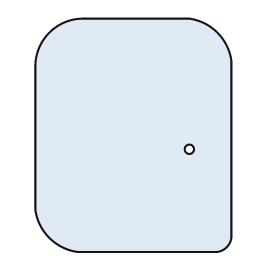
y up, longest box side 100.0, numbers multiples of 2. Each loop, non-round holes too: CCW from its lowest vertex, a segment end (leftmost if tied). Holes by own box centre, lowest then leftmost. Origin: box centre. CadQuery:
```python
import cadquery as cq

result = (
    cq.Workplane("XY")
    .moveTo(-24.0, -50.0)
    .lineTo(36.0, -50.0)
    .threePointArc((40.0, -48.0), (42.0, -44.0))
    .lineTo(42.0, 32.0)
    .threePointArc((36.0, 44.0), (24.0, 50.0))
    .lineTo(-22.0, 50.0)
    .threePointArc((-36.0, 44.0), (-42.0, 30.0))
    .lineTo(-42.0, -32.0)
    .threePointArc((-36.0, -44.0), (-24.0, -50.0))
    .close()
    .moveTo(24.0, -6.0)
    .circle(2.0)
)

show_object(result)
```